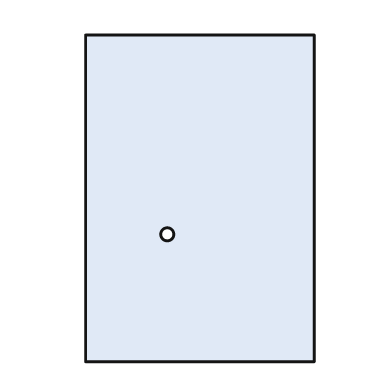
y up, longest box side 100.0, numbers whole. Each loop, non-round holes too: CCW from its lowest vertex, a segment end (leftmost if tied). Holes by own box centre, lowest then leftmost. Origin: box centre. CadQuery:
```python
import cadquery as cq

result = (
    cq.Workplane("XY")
    .moveTo(-35.0, -50.0)
    .lineTo(35.0, -50.0)
    .lineTo(35.0, 50.0)
    .lineTo(-35.0, 50.0)
    .close()
    .moveTo(-10.0, -11.0)
    .circle(2.0)
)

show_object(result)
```